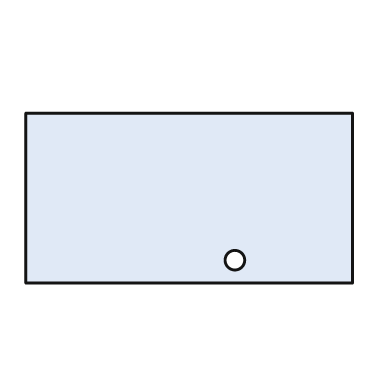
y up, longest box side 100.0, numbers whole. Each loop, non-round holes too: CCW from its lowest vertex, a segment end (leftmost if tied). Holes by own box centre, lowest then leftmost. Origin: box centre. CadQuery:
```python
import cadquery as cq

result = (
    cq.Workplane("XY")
    .moveTo(-50.0, -26.0)
    .lineTo(50.0, -26.0)
    .lineTo(50.0, 26.0)
    .lineTo(-50.0, 26.0)
    .close()
    .moveTo(14.0, -19.0)
    .circle(3.0)
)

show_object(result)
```